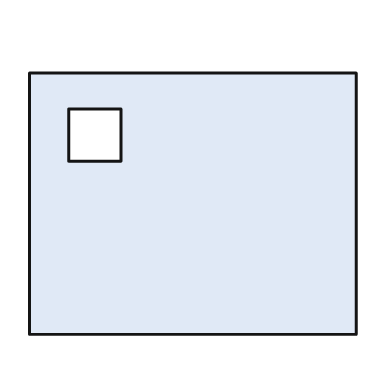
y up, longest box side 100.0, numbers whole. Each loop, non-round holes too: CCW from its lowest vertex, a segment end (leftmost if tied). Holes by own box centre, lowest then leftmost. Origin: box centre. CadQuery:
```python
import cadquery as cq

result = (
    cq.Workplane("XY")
    .moveTo(-50.0, -40.0)
    .lineTo(50.0, -40.0)
    .lineTo(50.0, 40.0)
    .lineTo(-50.0, 40.0)
    .close()
    .moveTo(-38.0, 13.0)
    .lineTo(-22.0, 13.0)
    .lineTo(-22.0, 29.0)
    .lineTo(-38.0, 29.0)
    .close()
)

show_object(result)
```